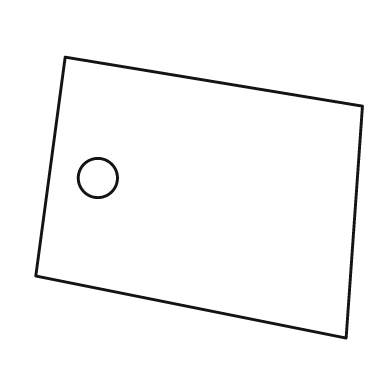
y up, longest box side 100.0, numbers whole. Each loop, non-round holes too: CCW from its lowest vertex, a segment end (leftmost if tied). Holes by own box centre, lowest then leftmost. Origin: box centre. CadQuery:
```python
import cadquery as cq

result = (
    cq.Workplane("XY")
    .moveTo(45.0, -43.0)
    .lineTo(50.0, 28.0)
    .lineTo(-41.0, 43.0)
    .lineTo(-50.0, -24.0)
    .close()
    .moveTo(-31.0, 6.0)
    .circle(6.0)
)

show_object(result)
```